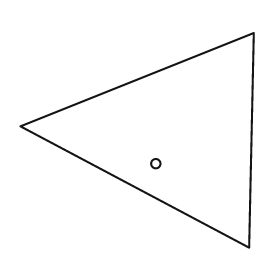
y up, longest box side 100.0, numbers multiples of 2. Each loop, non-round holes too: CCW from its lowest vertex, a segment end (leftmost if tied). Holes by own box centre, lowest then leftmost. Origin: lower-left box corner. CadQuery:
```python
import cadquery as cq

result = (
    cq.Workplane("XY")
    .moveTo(98.0, 0.0)
    .lineTo(100.0, 92.0)
    .lineTo(0.0, 52.0)
    .close()
    .moveTo(58.0, 36.0)
    .circle(2.0)
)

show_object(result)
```